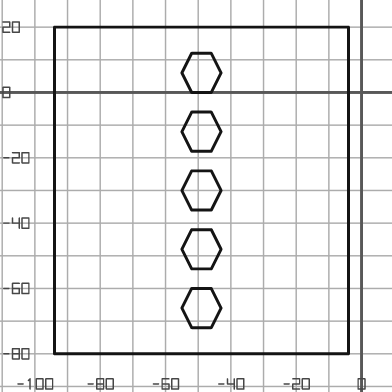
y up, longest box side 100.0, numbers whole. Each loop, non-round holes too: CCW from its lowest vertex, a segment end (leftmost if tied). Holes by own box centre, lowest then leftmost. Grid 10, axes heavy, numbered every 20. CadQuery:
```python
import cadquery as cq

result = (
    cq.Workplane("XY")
    .moveTo(-94.0, -80.0)
    .lineTo(-4.0, -80.0)
    .lineTo(-4.0, 20.0)
    .lineTo(-94.0, 20.0)
    .close()
    .moveTo(-52.0, -72.0)
    .lineTo(-46.0, -72.0)
    .lineTo(-43.0, -66.0)
    .lineTo(-46.0, -60.0)
    .lineTo(-52.0, -60.0)
    .lineTo(-55.0, -66.0)
    .close()
    .moveTo(-52.0, -54.0)
    .lineTo(-46.0, -54.0)
    .lineTo(-43.0, -48.0)
    .lineTo(-46.0, -42.0)
    .lineTo(-52.0, -42.0)
    .lineTo(-55.0, -48.0)
    .close()
    .moveTo(-52.0, -36.0)
    .lineTo(-46.0, -36.0)
    .lineTo(-43.0, -30.0)
    .lineTo(-46.0, -24.0)
    .lineTo(-52.0, -24.0)
    .lineTo(-55.0, -30.0)
    .close()
    .moveTo(-52.0, -18.0)
    .lineTo(-46.0, -18.0)
    .lineTo(-43.0, -12.0)
    .lineTo(-46.0, -6.0)
    .lineTo(-52.0, -6.0)
    .lineTo(-55.0, -12.0)
    .close()
    .moveTo(-52.0, 0.0)
    .lineTo(-46.0, 0.0)
    .lineTo(-43.0, 6.0)
    .lineTo(-46.0, 12.0)
    .lineTo(-52.0, 12.0)
    .lineTo(-55.0, 6.0)
    .close()
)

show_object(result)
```